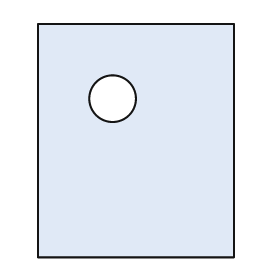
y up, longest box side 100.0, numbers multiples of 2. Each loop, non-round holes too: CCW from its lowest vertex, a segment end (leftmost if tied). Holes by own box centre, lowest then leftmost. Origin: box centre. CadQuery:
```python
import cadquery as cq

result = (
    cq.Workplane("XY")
    .moveTo(-42.0, -50.0)
    .lineTo(42.0, -50.0)
    .lineTo(42.0, 50.0)
    .lineTo(-42.0, 50.0)
    .close()
    .moveTo(-10.0, 18.0)
    .circle(10.0)
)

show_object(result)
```